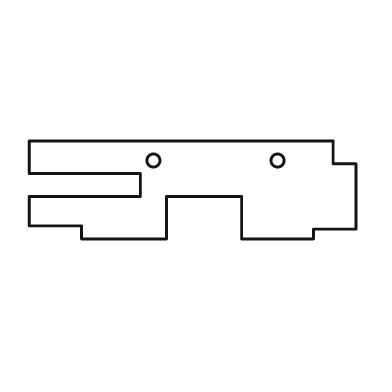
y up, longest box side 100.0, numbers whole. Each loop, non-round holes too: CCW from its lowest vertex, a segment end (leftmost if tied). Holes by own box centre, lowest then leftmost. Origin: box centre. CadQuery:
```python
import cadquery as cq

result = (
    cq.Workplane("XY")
    .moveTo(-34.0, -15.0)
    .lineTo(-8.0, -15.0)
    .lineTo(-8.0, -2.0)
    .lineTo(15.0, -2.0)
    .lineTo(15.0, -15.0)
    .lineTo(37.0, -15.0)
    .lineTo(37.0, -12.0)
    .lineTo(50.0, -12.0)
    .lineTo(50.0, 8.0)
    .lineTo(43.0, 8.0)
    .lineTo(43.0, 15.0)
    .lineTo(-50.0, 15.0)
    .lineTo(-50.0, 5.0)
    .lineTo(-16.0, 5.0)
    .lineTo(-16.0, -2.0)
    .lineTo(-50.0, -2.0)
    .lineTo(-50.0, -11.0)
    .lineTo(-34.0, -11.0)
    .close()
    .moveTo(-12.0, 9.0)
    .circle(2.0)
    .moveTo(26.0, 9.0)
    .circle(2.0)
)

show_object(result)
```